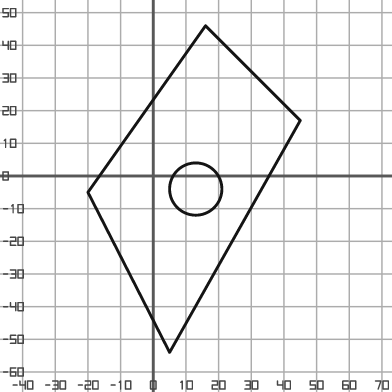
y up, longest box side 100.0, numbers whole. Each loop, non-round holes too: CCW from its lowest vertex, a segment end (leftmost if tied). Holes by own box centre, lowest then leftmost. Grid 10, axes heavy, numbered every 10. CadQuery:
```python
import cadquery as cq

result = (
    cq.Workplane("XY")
    .moveTo(5.0, -54.0)
    .lineTo(45.0, 17.0)
    .lineTo(16.0, 46.0)
    .lineTo(-20.0, -5.0)
    .close()
    .moveTo(13.0, -4.0)
    .circle(8.0)
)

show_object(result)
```